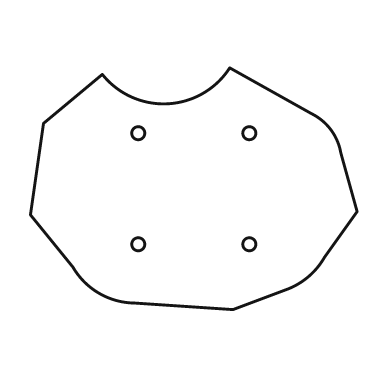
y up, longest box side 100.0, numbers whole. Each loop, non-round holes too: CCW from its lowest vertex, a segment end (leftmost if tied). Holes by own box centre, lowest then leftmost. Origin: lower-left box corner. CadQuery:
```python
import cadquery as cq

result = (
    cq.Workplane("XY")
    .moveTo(62.0, 0.0)
    .lineTo(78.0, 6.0)
    .threePointArc((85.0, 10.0), (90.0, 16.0))
    .lineTo(100.0, 30.0)
    .lineTo(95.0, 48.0)
    .threePointArc((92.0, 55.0), (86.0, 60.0))
    .lineTo(61.0, 74.0)
    .threePointArc((42.0, 63.0), (22.0, 72.0))
    .lineTo(4.0, 57.0)
    .lineTo(0.0, 29.0)
    .lineTo(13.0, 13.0)
    .threePointArc((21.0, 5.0), (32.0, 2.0))
    .close()
    .moveTo(33.0, 20.0)
    .circle(2.0)
    .moveTo(67.0, 20.0)
    .circle(2.0)
    .moveTo(33.0, 54.0)
    .circle(2.0)
    .moveTo(67.0, 54.0)
    .circle(2.0)
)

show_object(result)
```